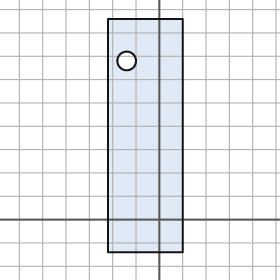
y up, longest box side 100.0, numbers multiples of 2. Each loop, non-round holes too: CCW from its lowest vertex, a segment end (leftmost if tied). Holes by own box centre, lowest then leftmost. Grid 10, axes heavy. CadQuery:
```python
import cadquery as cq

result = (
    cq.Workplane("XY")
    .moveTo(-22.0, -14.0)
    .lineTo(10.0, -14.0)
    .lineTo(10.0, 86.0)
    .lineTo(-22.0, 86.0)
    .close()
    .moveTo(-14.0, 68.0)
    .circle(4.0)
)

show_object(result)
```